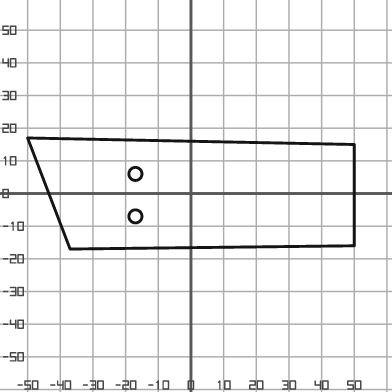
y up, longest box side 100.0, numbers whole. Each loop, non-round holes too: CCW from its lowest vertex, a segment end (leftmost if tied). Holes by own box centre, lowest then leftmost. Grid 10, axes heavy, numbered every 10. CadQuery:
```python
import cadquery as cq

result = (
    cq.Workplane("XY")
    .moveTo(-37.0, -17.0)
    .lineTo(50.0, -16.0)
    .lineTo(50.0, 15.0)
    .lineTo(-50.0, 17.0)
    .close()
    .moveTo(-17.0, -7.0)
    .circle(2.0)
    .moveTo(-17.0, 6.0)
    .circle(2.0)
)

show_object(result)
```